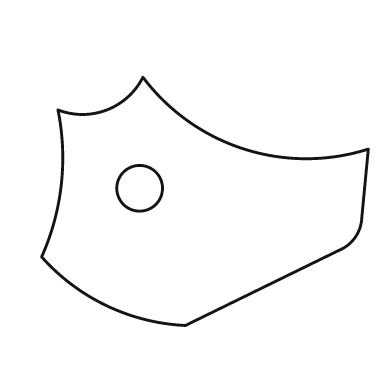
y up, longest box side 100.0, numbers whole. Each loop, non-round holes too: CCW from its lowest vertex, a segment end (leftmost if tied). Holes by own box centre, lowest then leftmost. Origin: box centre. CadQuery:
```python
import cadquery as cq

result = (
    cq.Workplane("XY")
    .moveTo(-6.0, -38.0)
    .lineTo(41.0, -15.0)
    .threePointArc((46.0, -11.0), (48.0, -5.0))
    .lineTo(50.0, 16.0)
    .threePointArc((12.0, 16.0), (-19.0, 38.0))
    .threePointArc((-30.0, 28.0), (-45.0, 28.0))
    .threePointArc((-44.0, 5.0), (-50.0, -17.0))
    .threePointArc((-30.0, -32.0), (-6.0, -38.0))
    .close()
    .moveTo(-20.0, 4.0)
    .circle(7.0)
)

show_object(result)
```